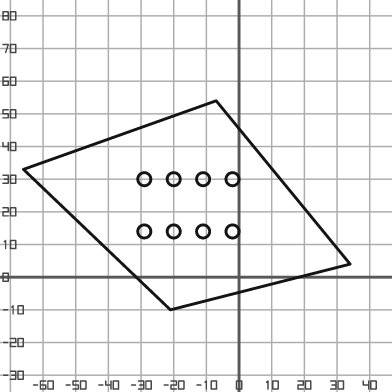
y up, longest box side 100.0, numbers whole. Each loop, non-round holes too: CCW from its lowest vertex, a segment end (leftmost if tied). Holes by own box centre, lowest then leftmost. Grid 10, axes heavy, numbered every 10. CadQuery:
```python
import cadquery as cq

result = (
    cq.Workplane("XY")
    .moveTo(-21.0, -10.0)
    .lineTo(34.0, 4.0)
    .lineTo(-7.0, 54.0)
    .lineTo(-66.0, 33.0)
    .close()
    .moveTo(-29.0, 14.0)
    .circle(2.0)
    .moveTo(-20.0, 14.0)
    .circle(2.0)
    .moveTo(-11.0, 14.0)
    .circle(2.0)
    .moveTo(-2.0, 14.0)
    .circle(2.0)
    .moveTo(-29.0, 30.0)
    .circle(2.0)
    .moveTo(-20.0, 30.0)
    .circle(2.0)
    .moveTo(-11.0, 30.0)
    .circle(2.0)
    .moveTo(-2.0, 30.0)
    .circle(2.0)
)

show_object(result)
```